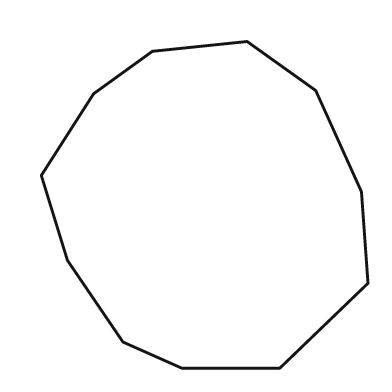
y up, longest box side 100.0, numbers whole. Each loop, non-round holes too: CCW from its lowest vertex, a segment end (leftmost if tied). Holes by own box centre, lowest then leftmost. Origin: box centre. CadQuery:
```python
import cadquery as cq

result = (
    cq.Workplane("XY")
    .moveTo(-7.0, -50.0)
    .lineTo(23.0, -50.0)
    .lineTo(50.0, -24.0)
    .lineTo(48.0, 4.0)
    .lineTo(34.0, 35.0)
    .lineTo(13.0, 50.0)
    .lineTo(-16.0, 47.0)
    .lineTo(-34.0, 34.0)
    .lineTo(-50.0, 9.0)
    .lineTo(-42.0, -17.0)
    .lineTo(-25.0, -42.0)
    .close()
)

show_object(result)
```